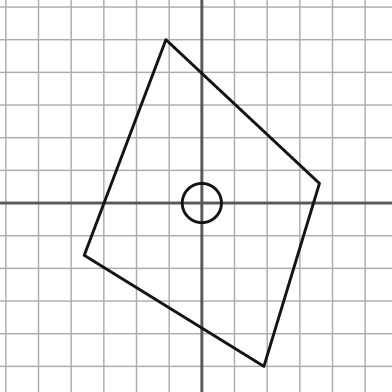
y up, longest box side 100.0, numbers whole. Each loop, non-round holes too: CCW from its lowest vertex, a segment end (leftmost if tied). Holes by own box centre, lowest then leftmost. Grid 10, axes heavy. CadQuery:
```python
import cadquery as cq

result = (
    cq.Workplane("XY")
    .moveTo(19.0, -50.0)
    .lineTo(36.0, 6.0)
    .lineTo(-11.0, 50.0)
    .lineTo(-36.0, -16.0)
    .close()
    .moveTo(0.0, 0.0)
    .circle(6.0)
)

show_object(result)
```